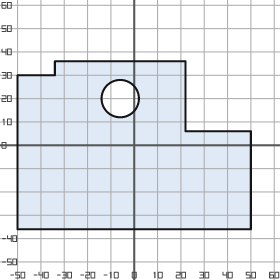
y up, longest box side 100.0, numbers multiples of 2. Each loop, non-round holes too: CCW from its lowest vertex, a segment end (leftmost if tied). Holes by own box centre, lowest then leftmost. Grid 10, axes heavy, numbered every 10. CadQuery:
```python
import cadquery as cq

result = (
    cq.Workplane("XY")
    .moveTo(-50.0, -36.0)
    .lineTo(50.0, -36.0)
    .lineTo(50.0, 6.0)
    .lineTo(22.0, 6.0)
    .lineTo(22.0, 36.0)
    .lineTo(-34.0, 36.0)
    .lineTo(-34.0, 30.0)
    .lineTo(-50.0, 30.0)
    .close()
    .moveTo(-6.0, 20.0)
    .circle(8.0)
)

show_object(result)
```